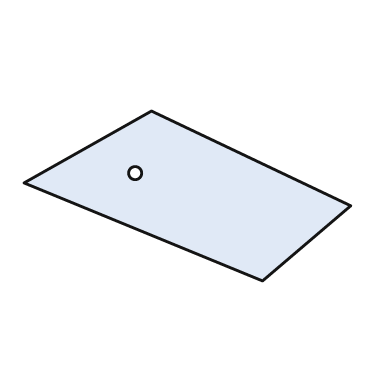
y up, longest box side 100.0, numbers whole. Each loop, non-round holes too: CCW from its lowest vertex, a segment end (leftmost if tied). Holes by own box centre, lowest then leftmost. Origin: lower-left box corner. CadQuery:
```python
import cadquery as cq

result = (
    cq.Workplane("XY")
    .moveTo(73.0, 0.0)
    .lineTo(100.0, 23.0)
    .lineTo(39.0, 52.0)
    .lineTo(0.0, 30.0)
    .close()
    .moveTo(34.0, 33.0)
    .circle(2.0)
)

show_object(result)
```